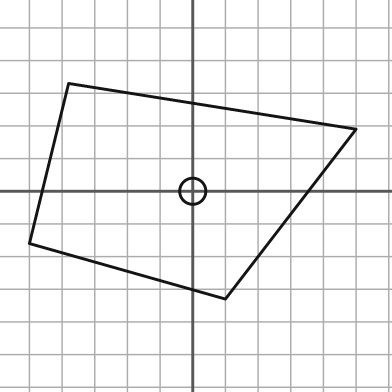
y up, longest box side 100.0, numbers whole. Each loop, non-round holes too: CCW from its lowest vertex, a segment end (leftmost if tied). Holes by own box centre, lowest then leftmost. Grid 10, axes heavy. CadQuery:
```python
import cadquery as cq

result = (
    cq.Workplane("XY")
    .moveTo(10.0, -33.0)
    .lineTo(50.0, 19.0)
    .lineTo(-38.0, 33.0)
    .lineTo(-50.0, -16.0)
    .close()
    .moveTo(0.0, 0.0)
    .circle(4.0)
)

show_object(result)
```